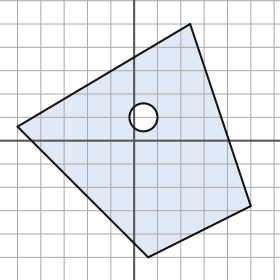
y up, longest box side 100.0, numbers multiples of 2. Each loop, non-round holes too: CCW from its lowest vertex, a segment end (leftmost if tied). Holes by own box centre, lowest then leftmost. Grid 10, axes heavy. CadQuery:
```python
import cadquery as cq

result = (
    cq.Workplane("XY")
    .moveTo(6.0, -50.0)
    .lineTo(50.0, -28.0)
    .lineTo(24.0, 50.0)
    .lineTo(-50.0, 6.0)
    .close()
    .moveTo(4.0, 10.0)
    .circle(6.0)
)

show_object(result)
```